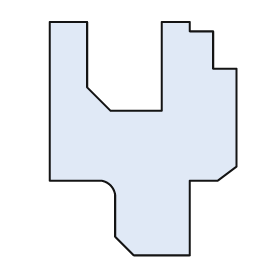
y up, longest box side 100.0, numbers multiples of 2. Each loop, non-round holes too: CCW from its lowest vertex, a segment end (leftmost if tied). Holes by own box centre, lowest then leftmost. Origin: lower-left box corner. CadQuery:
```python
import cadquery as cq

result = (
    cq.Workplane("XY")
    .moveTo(36.0, 0.0)
    .lineTo(60.0, 0.0)
    .lineTo(60.0, 32.0)
    .lineTo(72.0, 32.0)
    .lineTo(80.0, 38.0)
    .lineTo(80.0, 80.0)
    .lineTo(70.0, 80.0)
    .lineTo(70.0, 96.0)
    .lineTo(60.0, 96.0)
    .lineTo(60.0, 100.0)
    .lineTo(48.0, 100.0)
    .lineTo(48.0, 62.0)
    .lineTo(26.0, 62.0)
    .lineTo(16.0, 72.0)
    .lineTo(16.0, 100.0)
    .lineTo(0.0, 100.0)
    .lineTo(0.0, 32.0)
    .lineTo(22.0, 32.0)
    .threePointArc((26.0, 30.0), (28.0, 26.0))
    .lineTo(28.0, 8.0)
    .close()
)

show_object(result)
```